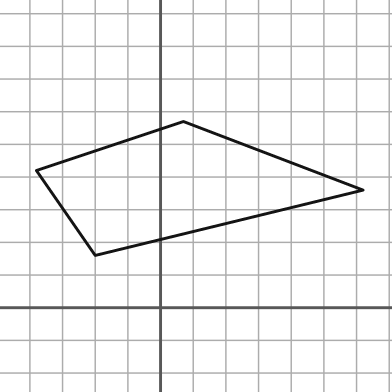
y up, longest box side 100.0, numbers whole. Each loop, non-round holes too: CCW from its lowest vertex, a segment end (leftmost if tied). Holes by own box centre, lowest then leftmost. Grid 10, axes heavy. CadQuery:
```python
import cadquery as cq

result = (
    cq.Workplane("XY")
    .moveTo(-20.0, 16.0)
    .lineTo(62.0, 36.0)
    .lineTo(7.0, 57.0)
    .lineTo(-38.0, 42.0)
    .close()
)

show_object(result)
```